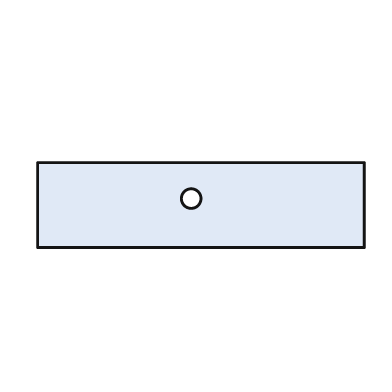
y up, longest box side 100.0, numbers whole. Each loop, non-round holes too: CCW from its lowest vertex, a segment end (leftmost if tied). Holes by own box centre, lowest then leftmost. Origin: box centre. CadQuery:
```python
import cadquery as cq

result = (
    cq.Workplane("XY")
    .moveTo(-50.0, -13.0)
    .lineTo(50.0, -13.0)
    .lineTo(50.0, 13.0)
    .lineTo(-50.0, 13.0)
    .close()
    .moveTo(-3.0, 2.0)
    .circle(3.0)
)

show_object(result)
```